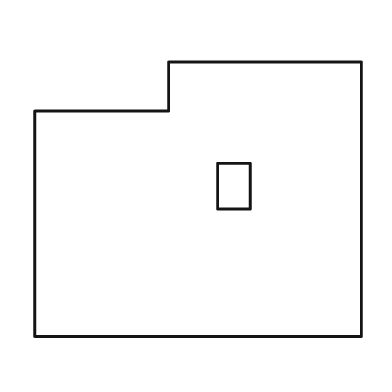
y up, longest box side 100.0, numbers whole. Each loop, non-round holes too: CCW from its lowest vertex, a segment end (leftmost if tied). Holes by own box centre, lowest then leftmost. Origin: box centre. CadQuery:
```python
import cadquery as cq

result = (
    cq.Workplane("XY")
    .moveTo(-50.0, -42.0)
    .lineTo(50.0, -42.0)
    .lineTo(50.0, 42.0)
    .lineTo(-9.0, 42.0)
    .lineTo(-9.0, 27.0)
    .lineTo(-50.0, 27.0)
    .close()
    .moveTo(6.0, -3.0)
    .lineTo(16.0, -3.0)
    .lineTo(16.0, 11.0)
    .lineTo(6.0, 11.0)
    .close()
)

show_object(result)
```